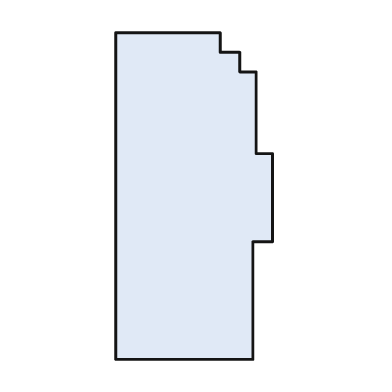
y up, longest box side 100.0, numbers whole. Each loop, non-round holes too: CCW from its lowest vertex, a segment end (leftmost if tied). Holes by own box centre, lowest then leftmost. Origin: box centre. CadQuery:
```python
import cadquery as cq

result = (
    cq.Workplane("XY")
    .moveTo(-24.0, -50.0)
    .lineTo(18.0, -50.0)
    .lineTo(18.0, -14.0)
    .lineTo(24.0, -14.0)
    .lineTo(24.0, 13.0)
    .lineTo(19.0, 13.0)
    .lineTo(19.0, 38.0)
    .lineTo(14.0, 38.0)
    .lineTo(14.0, 44.0)
    .lineTo(8.0, 44.0)
    .lineTo(8.0, 50.0)
    .lineTo(-24.0, 50.0)
    .close()
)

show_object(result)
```